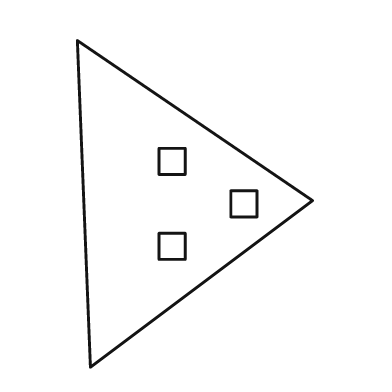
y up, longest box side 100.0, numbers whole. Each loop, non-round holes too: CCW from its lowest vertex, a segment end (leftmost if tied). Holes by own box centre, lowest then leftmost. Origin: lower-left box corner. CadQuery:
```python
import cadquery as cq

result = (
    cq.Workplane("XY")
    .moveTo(4.0, 0.0)
    .lineTo(72.0, 51.0)
    .lineTo(0.0, 100.0)
    .close()
    .moveTo(25.0, 33.0)
    .lineTo(33.0, 33.0)
    .lineTo(33.0, 41.0)
    .lineTo(25.0, 41.0)
    .close()
    .moveTo(47.0, 46.0)
    .lineTo(55.0, 46.0)
    .lineTo(55.0, 54.0)
    .lineTo(47.0, 54.0)
    .close()
    .moveTo(25.0, 59.0)
    .lineTo(33.0, 59.0)
    .lineTo(33.0, 67.0)
    .lineTo(25.0, 67.0)
    .close()
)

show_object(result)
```